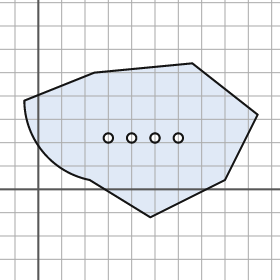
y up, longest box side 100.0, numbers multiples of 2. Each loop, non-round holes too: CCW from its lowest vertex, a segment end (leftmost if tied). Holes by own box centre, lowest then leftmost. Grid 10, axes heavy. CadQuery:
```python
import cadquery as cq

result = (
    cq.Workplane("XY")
    .moveTo(48.0, -12.0)
    .lineTo(80.0, 4.0)
    .lineTo(94.0, 32.0)
    .lineTo(66.0, 54.0)
    .lineTo(24.0, 50.0)
    .lineTo(-6.0, 38.0)
    .threePointArc((2.0, 16.0), (22.0, 4.0))
    .close()
    .moveTo(30.0, 22.0)
    .circle(2.0)
    .moveTo(40.0, 22.0)
    .circle(2.0)
    .moveTo(50.0, 22.0)
    .circle(2.0)
    .moveTo(60.0, 22.0)
    .circle(2.0)
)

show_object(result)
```